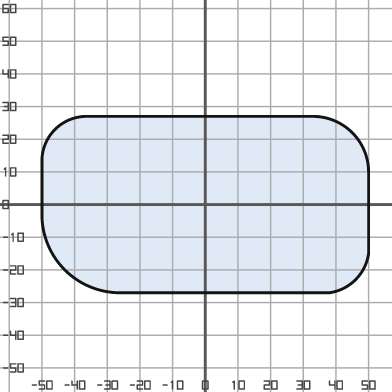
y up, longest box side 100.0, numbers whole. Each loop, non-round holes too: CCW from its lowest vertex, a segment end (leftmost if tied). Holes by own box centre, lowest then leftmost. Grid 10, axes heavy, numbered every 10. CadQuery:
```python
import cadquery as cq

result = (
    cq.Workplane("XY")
    .moveTo(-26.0, -27.0)
    .lineTo(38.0, -27.0)
    .threePointArc((46.0, -23.0), (50.0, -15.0))
    .lineTo(50.0, 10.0)
    .threePointArc((45.0, 22.0), (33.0, 27.0))
    .lineTo(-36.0, 27.0)
    .threePointArc((-46.0, 23.0), (-50.0, 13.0))
    .lineTo(-50.0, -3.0)
    .threePointArc((-43.0, -20.0), (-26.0, -27.0))
    .close()
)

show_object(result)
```